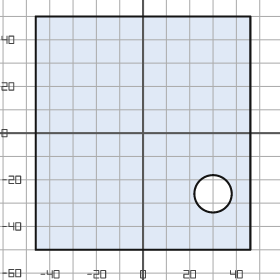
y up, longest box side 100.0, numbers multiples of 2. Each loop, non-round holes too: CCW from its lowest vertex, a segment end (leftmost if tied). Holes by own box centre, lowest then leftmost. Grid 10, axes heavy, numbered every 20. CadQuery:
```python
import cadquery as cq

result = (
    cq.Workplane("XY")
    .moveTo(-46.0, -50.0)
    .lineTo(46.0, -50.0)
    .lineTo(46.0, 50.0)
    .lineTo(-46.0, 50.0)
    .close()
    .moveTo(30.0, -26.0)
    .circle(8.0)
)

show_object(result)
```